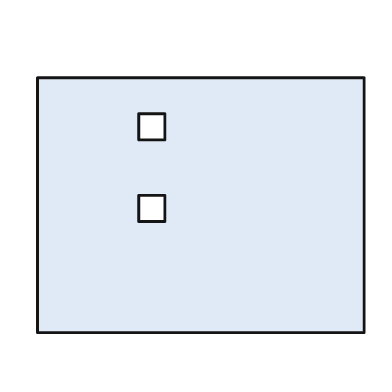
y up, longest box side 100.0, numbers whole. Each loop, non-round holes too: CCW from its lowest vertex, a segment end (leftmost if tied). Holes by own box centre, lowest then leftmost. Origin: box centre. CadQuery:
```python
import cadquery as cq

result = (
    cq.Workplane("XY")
    .moveTo(-50.0, -39.0)
    .lineTo(50.0, -39.0)
    .lineTo(50.0, 39.0)
    .lineTo(-50.0, 39.0)
    .close()
    .moveTo(-19.0, -5.0)
    .lineTo(-11.0, -5.0)
    .lineTo(-11.0, 3.0)
    .lineTo(-19.0, 3.0)
    .close()
    .moveTo(-19.0, 20.0)
    .lineTo(-11.0, 20.0)
    .lineTo(-11.0, 28.0)
    .lineTo(-19.0, 28.0)
    .close()
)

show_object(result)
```